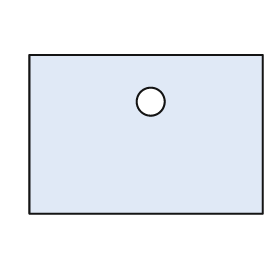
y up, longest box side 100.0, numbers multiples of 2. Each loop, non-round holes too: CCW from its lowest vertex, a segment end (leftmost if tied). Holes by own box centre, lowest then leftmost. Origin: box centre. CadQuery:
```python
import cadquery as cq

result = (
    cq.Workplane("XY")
    .moveTo(-50.0, -34.0)
    .lineTo(50.0, -34.0)
    .lineTo(50.0, 34.0)
    .lineTo(-50.0, 34.0)
    .close()
    .moveTo(2.0, 14.0)
    .circle(6.0)
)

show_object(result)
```